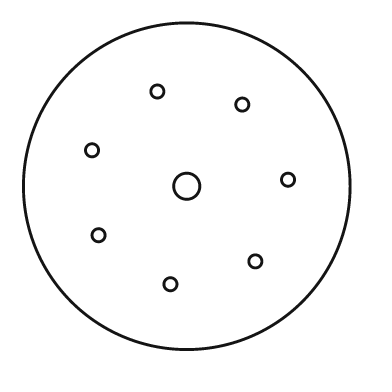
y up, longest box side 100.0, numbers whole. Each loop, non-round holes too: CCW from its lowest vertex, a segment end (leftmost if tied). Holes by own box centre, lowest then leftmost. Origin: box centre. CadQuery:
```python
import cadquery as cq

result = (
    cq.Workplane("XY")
    .moveTo(0.0, 0.0)
    .circle(50.0)
    .moveTo(-5.0, -30.0)
    .circle(2.0)
    .moveTo(21.0, -23.0)
    .circle(2.0)
    .moveTo(-27.0, -15.0)
    .circle(2.0)
    .moveTo(0.0, 0.0)
    .circle(4.0)
    .moveTo(31.0, 2.0)
    .circle(2.0)
    .moveTo(-29.0, 11.0)
    .circle(2.0)
    .moveTo(17.0, 25.0)
    .circle(2.0)
    .moveTo(-9.0, 29.0)
    .circle(2.0)
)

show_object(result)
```